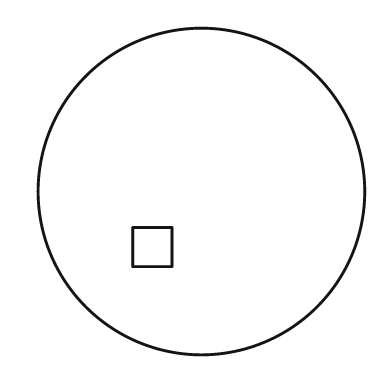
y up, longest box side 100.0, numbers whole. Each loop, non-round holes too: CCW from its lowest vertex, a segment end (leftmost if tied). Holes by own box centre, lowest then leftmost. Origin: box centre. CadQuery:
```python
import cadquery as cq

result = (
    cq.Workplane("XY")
    .moveTo(0.0, 0.0)
    .circle(50.0)
    .moveTo(-21.0, -23.0)
    .lineTo(-9.0, -23.0)
    .lineTo(-9.0, -11.0)
    .lineTo(-21.0, -11.0)
    .close()
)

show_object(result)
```